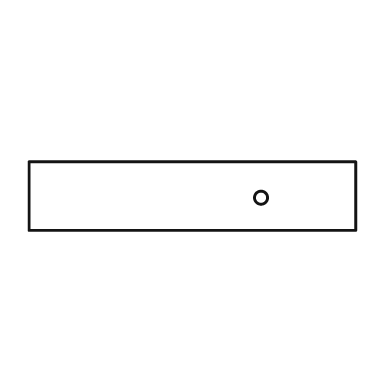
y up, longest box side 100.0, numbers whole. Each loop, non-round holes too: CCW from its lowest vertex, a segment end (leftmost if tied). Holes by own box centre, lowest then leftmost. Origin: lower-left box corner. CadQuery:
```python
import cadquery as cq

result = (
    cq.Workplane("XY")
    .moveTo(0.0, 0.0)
    .lineTo(100.0, 0.0)
    .lineTo(100.0, 21.0)
    .lineTo(0.0, 21.0)
    .close()
    .moveTo(71.0, 10.0)
    .circle(2.0)
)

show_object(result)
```